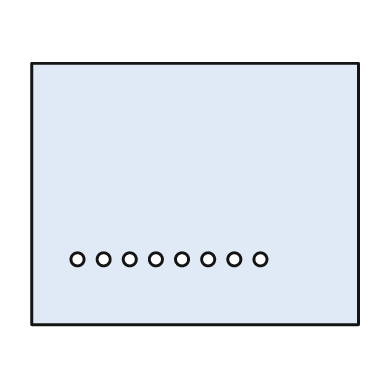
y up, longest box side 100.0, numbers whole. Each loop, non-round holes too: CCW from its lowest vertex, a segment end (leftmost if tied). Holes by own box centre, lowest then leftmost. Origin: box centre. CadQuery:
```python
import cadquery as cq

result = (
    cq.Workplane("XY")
    .moveTo(-50.0, -40.0)
    .lineTo(50.0, -40.0)
    .lineTo(50.0, 40.0)
    .lineTo(-50.0, 40.0)
    .close()
    .moveTo(-36.0, -20.0)
    .circle(2.0)
    .moveTo(-28.0, -20.0)
    .circle(2.0)
    .moveTo(-20.0, -20.0)
    .circle(2.0)
    .moveTo(-12.0, -20.0)
    .circle(2.0)
    .moveTo(-4.0, -20.0)
    .circle(2.0)
    .moveTo(4.0, -20.0)
    .circle(2.0)
    .moveTo(12.0, -20.0)
    .circle(2.0)
    .moveTo(20.0, -20.0)
    .circle(2.0)
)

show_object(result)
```